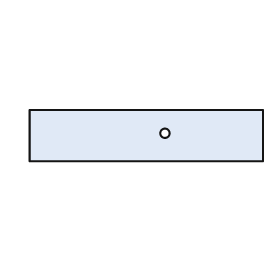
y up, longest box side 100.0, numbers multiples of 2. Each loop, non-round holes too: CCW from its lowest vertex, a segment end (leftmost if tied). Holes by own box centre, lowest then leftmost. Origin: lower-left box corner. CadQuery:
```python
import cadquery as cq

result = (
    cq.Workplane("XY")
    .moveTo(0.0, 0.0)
    .lineTo(100.0, 0.0)
    .lineTo(100.0, 22.0)
    .lineTo(0.0, 22.0)
    .close()
    .moveTo(58.0, 12.0)
    .circle(2.0)
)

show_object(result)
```